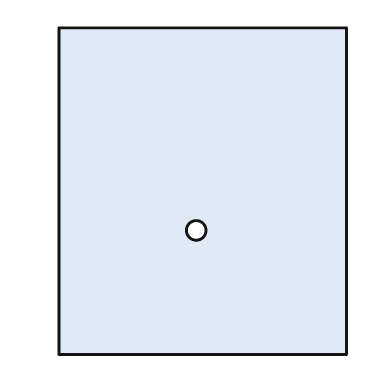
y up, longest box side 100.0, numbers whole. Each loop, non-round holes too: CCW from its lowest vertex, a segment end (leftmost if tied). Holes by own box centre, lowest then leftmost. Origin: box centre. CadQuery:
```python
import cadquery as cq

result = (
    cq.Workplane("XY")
    .moveTo(-44.0, -50.0)
    .lineTo(44.0, -50.0)
    .lineTo(44.0, 50.0)
    .lineTo(-44.0, 50.0)
    .close()
    .moveTo(-2.0, -12.0)
    .circle(3.0)
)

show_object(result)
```